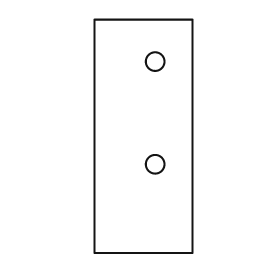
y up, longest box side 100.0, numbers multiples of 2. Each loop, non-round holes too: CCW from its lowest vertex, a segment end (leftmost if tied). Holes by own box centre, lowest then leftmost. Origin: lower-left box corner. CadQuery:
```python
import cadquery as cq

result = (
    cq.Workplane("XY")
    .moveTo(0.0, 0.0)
    .lineTo(42.0, 0.0)
    .lineTo(42.0, 100.0)
    .lineTo(0.0, 100.0)
    .close()
    .moveTo(26.0, 38.0)
    .circle(4.0)
    .moveTo(26.0, 82.0)
    .circle(4.0)
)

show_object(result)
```